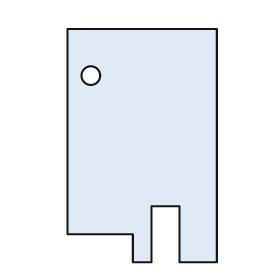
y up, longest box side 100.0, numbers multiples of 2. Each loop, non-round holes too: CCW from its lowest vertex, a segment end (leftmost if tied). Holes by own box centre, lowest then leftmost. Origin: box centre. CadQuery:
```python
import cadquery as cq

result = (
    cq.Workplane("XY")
    .moveTo(-4.0, -50.0)
    .lineTo(4.0, -50.0)
    .lineTo(4.0, -26.0)
    .lineTo(16.0, -26.0)
    .lineTo(16.0, -50.0)
    .lineTo(32.0, -50.0)
    .lineTo(32.0, 50.0)
    .lineTo(-32.0, 50.0)
    .lineTo(-32.0, -38.0)
    .lineTo(-4.0, -38.0)
    .close()
    .moveTo(-22.0, 30.0)
    .circle(4.0)
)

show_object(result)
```